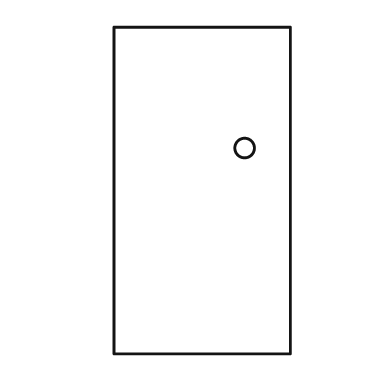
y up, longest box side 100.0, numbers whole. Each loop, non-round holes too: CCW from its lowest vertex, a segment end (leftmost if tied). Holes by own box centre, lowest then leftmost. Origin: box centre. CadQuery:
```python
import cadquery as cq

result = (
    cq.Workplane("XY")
    .moveTo(-27.0, -50.0)
    .lineTo(27.0, -50.0)
    .lineTo(27.0, 50.0)
    .lineTo(-27.0, 50.0)
    .close()
    .moveTo(13.0, 13.0)
    .circle(3.0)
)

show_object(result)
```